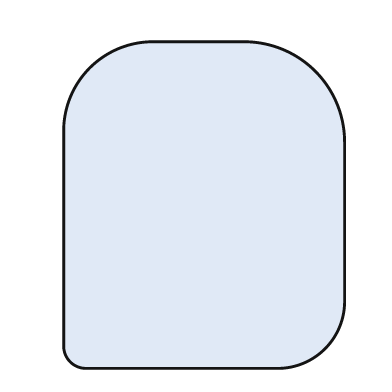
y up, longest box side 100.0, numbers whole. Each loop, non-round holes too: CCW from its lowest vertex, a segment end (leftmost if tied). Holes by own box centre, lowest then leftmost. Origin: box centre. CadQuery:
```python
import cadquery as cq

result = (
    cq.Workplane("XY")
    .moveTo(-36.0, -50.0)
    .lineTo(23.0, -50.0)
    .threePointArc((37.0, -44.0), (43.0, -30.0))
    .lineTo(43.0, 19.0)
    .threePointArc((34.0, 41.0), (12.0, 50.0))
    .lineTo(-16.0, 50.0)
    .threePointArc((-35.0, 42.0), (-43.0, 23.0))
    .lineTo(-43.0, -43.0)
    .threePointArc((-41.0, -48.0), (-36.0, -50.0))
    .close()
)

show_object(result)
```